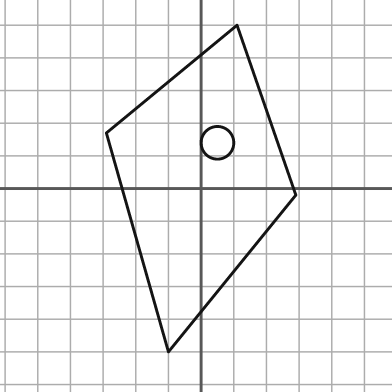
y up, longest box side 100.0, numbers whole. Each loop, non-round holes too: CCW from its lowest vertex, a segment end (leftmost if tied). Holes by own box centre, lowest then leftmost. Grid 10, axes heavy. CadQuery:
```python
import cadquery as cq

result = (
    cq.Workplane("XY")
    .moveTo(-10.0, -50.0)
    .lineTo(29.0, -2.0)
    .lineTo(11.0, 50.0)
    .lineTo(-29.0, 17.0)
    .close()
    .moveTo(5.0, 14.0)
    .circle(5.0)
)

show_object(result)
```